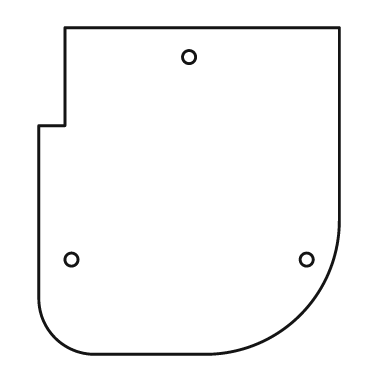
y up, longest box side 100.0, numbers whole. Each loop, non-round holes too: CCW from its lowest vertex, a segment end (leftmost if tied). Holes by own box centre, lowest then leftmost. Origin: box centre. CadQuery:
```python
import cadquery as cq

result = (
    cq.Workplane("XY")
    .moveTo(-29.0, -50.0)
    .lineTo(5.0, -50.0)
    .threePointArc((34.0, -38.0), (46.0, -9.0))
    .lineTo(46.0, 50.0)
    .lineTo(-38.0, 50.0)
    .lineTo(-38.0, 20.0)
    .lineTo(-46.0, 20.0)
    .lineTo(-46.0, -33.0)
    .threePointArc((-41.0, -45.0), (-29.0, -50.0))
    .close()
    .moveTo(-36.0, -21.0)
    .circle(2.0)
    .moveTo(36.0, -21.0)
    .circle(2.0)
    .moveTo(0.0, 41.0)
    .circle(2.0)
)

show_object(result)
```